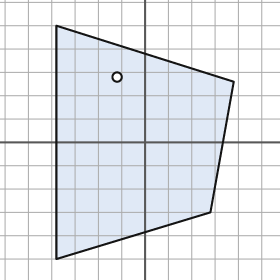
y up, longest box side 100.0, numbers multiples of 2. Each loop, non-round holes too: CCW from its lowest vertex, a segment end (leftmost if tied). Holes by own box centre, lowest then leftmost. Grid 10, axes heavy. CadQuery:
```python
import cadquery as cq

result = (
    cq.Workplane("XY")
    .moveTo(-38.0, -50.0)
    .lineTo(28.0, -30.0)
    .lineTo(38.0, 26.0)
    .lineTo(-38.0, 50.0)
    .close()
    .moveTo(-12.0, 28.0)
    .circle(2.0)
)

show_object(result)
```